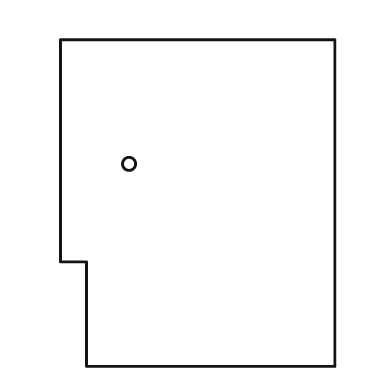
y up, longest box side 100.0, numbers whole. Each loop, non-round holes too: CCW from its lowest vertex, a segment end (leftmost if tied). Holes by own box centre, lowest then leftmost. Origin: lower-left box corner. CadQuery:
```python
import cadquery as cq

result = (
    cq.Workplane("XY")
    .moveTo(8.0, 0.0)
    .lineTo(84.0, 0.0)
    .lineTo(84.0, 100.0)
    .lineTo(0.0, 100.0)
    .lineTo(0.0, 32.0)
    .lineTo(8.0, 32.0)
    .close()
    .moveTo(21.0, 62.0)
    .circle(2.0)
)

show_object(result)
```